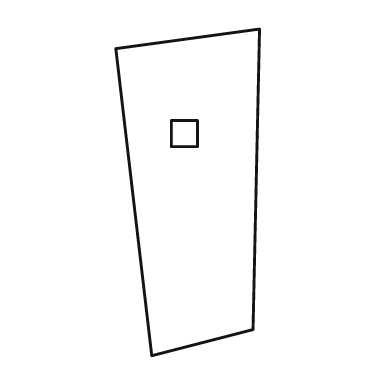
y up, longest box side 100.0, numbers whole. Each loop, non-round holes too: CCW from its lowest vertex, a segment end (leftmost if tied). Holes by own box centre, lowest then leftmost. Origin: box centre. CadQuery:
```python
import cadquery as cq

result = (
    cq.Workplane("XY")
    .moveTo(-11.0, -50.0)
    .lineTo(20.0, -42.0)
    .lineTo(22.0, 50.0)
    .lineTo(-22.0, 44.0)
    .close()
    .moveTo(-5.0, 14.0)
    .lineTo(3.0, 14.0)
    .lineTo(3.0, 22.0)
    .lineTo(-5.0, 22.0)
    .close()
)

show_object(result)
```